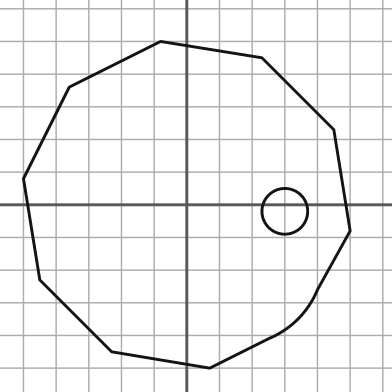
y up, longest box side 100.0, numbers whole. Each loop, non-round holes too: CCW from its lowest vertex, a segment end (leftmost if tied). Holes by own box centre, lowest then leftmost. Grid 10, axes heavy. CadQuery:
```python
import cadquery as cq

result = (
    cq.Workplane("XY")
    .moveTo(7.0, -50.0)
    .lineTo(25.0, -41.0)
    .threePointArc((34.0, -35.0), (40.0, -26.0))
    .lineTo(50.0, -8.0)
    .lineTo(45.0, 23.0)
    .lineTo(23.0, 45.0)
    .lineTo(-8.0, 50.0)
    .lineTo(-36.0, 36.0)
    .lineTo(-50.0, 8.0)
    .lineTo(-45.0, -23.0)
    .lineTo(-23.0, -45.0)
    .close()
    .moveTo(30.0, -2.0)
    .circle(7.0)
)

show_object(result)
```